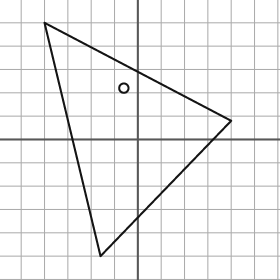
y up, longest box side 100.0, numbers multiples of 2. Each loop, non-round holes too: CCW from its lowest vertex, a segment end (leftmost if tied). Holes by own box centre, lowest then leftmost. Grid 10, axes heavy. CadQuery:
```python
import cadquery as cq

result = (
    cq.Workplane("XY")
    .moveTo(-16.0, -50.0)
    .lineTo(40.0, 8.0)
    .lineTo(-40.0, 50.0)
    .close()
    .moveTo(-6.0, 22.0)
    .circle(2.0)
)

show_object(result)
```